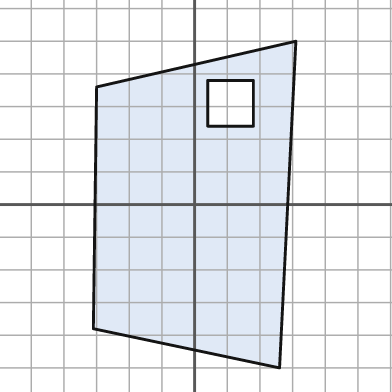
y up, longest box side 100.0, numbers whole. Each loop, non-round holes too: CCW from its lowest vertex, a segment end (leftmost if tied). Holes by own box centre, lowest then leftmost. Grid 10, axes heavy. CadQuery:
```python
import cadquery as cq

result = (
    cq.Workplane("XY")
    .moveTo(26.0, -50.0)
    .lineTo(31.0, 50.0)
    .lineTo(-30.0, 36.0)
    .lineTo(-31.0, -38.0)
    .close()
    .moveTo(4.0, 24.0)
    .lineTo(18.0, 24.0)
    .lineTo(18.0, 38.0)
    .lineTo(4.0, 38.0)
    .close()
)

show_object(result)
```